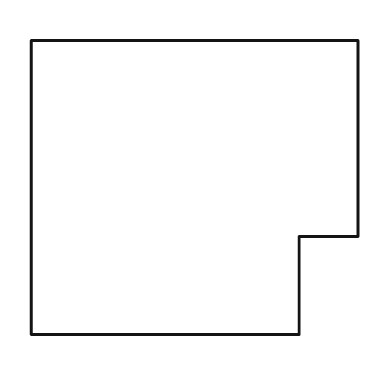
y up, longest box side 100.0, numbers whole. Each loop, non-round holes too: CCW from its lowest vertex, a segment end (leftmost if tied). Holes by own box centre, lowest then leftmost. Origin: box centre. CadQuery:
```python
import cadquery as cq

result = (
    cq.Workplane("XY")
    .moveTo(-50.0, -45.0)
    .lineTo(32.0, -45.0)
    .lineTo(32.0, -15.0)
    .lineTo(50.0, -15.0)
    .lineTo(50.0, 45.0)
    .lineTo(-50.0, 45.0)
    .close()
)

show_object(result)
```